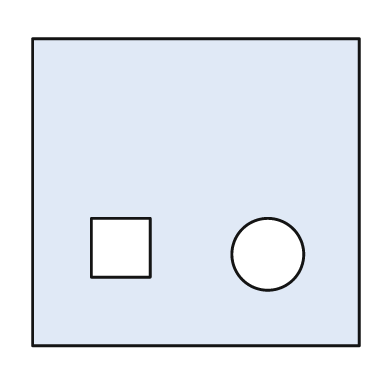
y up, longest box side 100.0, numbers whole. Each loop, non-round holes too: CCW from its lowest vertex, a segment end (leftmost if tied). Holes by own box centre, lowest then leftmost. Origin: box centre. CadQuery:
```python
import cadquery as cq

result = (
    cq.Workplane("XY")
    .moveTo(-50.0, -47.0)
    .lineTo(50.0, -47.0)
    .lineTo(50.0, 47.0)
    .lineTo(-50.0, 47.0)
    .close()
    .moveTo(22.0, -19.0)
    .circle(11.0)
    .moveTo(-32.0, -26.0)
    .lineTo(-14.0, -26.0)
    .lineTo(-14.0, -8.0)
    .lineTo(-32.0, -8.0)
    .close()
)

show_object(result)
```